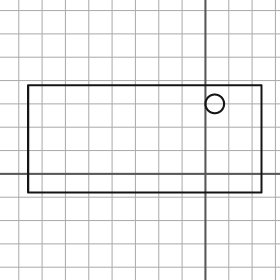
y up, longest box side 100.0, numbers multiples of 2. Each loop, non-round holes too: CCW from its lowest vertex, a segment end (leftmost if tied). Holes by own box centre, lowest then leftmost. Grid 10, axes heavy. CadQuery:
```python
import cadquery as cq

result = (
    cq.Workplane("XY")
    .moveTo(-76.0, -8.0)
    .lineTo(24.0, -8.0)
    .lineTo(24.0, 38.0)
    .lineTo(-76.0, 38.0)
    .close()
    .moveTo(4.0, 30.0)
    .circle(4.0)
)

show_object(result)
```